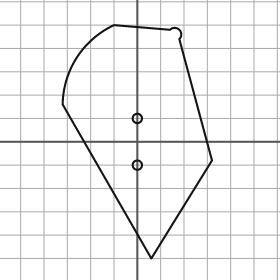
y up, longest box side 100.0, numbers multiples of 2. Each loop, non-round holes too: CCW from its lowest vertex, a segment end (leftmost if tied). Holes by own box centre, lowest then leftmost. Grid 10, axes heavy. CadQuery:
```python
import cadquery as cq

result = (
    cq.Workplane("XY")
    .moveTo(6.0, -50.0)
    .lineTo(32.0, -8.0)
    .lineTo(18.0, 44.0)
    .threePointArc((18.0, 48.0), (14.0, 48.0))
    .lineTo(-10.0, 50.0)
    .threePointArc((-26.0, 36.0), (-32.0, 16.0))
    .close()
    .moveTo(0.0, -10.0)
    .circle(2.0)
    .moveTo(0.0, 10.0)
    .circle(2.0)
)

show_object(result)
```